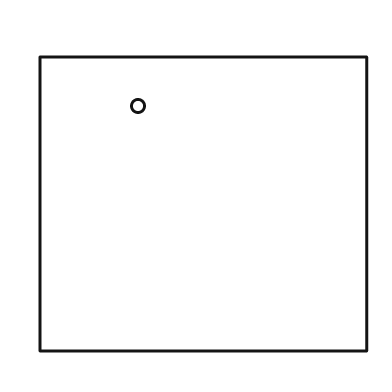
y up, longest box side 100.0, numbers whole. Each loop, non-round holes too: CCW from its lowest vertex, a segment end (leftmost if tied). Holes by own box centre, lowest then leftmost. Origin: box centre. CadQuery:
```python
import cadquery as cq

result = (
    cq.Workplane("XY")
    .moveTo(-50.0, -45.0)
    .lineTo(50.0, -45.0)
    .lineTo(50.0, 45.0)
    .lineTo(-50.0, 45.0)
    .close()
    .moveTo(-20.0, 30.0)
    .circle(2.0)
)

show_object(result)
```